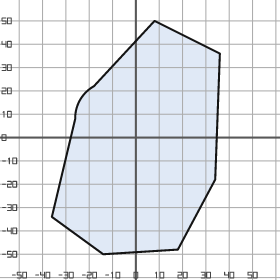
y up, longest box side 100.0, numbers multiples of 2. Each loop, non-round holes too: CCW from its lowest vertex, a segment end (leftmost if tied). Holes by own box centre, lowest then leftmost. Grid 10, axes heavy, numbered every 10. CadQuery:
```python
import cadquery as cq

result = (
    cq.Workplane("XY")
    .moveTo(-14.0, -50.0)
    .lineTo(18.0, -48.0)
    .lineTo(34.0, -18.0)
    .lineTo(36.0, 36.0)
    .lineTo(8.0, 50.0)
    .lineTo(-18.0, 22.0)
    .threePointArc((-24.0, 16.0), (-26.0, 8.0))
    .lineTo(-36.0, -34.0)
    .close()
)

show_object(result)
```